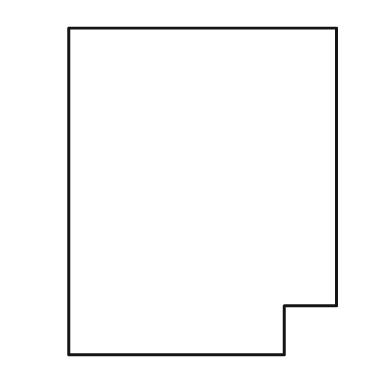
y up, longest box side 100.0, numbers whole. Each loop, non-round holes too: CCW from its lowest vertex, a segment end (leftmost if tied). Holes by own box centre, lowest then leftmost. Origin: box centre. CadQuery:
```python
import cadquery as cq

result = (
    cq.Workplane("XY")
    .moveTo(-41.0, -50.0)
    .lineTo(25.0, -50.0)
    .lineTo(25.0, -35.0)
    .lineTo(41.0, -35.0)
    .lineTo(41.0, 50.0)
    .lineTo(-41.0, 50.0)
    .close()
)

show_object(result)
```